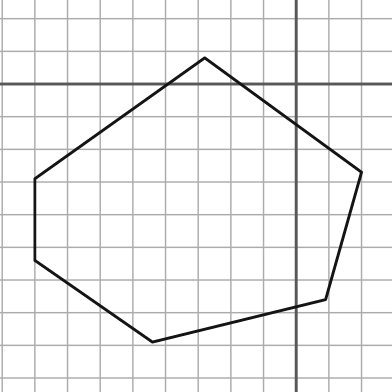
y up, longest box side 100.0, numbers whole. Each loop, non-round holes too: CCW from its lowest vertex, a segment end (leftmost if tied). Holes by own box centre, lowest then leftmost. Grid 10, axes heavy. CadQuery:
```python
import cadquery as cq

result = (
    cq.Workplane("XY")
    .moveTo(-44.0, -79.0)
    .lineTo(9.0, -66.0)
    .lineTo(20.0, -27.0)
    .lineTo(-28.0, 8.0)
    .lineTo(-80.0, -29.0)
    .lineTo(-80.0, -54.0)
    .close()
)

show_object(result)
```